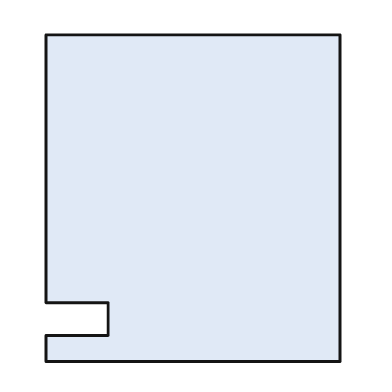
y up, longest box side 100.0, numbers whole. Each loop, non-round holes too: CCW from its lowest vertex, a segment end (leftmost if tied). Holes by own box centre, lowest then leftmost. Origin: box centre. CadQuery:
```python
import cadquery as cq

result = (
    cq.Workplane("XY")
    .moveTo(-45.0, -50.0)
    .lineTo(45.0, -50.0)
    .lineTo(45.0, 50.0)
    .lineTo(-45.0, 50.0)
    .lineTo(-45.0, -32.0)
    .lineTo(-26.0, -32.0)
    .lineTo(-26.0, -42.0)
    .lineTo(-45.0, -42.0)
    .close()
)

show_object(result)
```